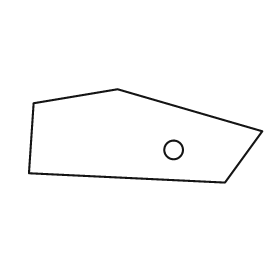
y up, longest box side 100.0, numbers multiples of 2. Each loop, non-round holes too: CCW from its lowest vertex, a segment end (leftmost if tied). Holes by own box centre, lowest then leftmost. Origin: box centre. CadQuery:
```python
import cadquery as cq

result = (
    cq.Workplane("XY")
    .moveTo(34.0, -20.0)
    .lineTo(50.0, 2.0)
    .lineTo(-12.0, 20.0)
    .lineTo(-48.0, 14.0)
    .lineTo(-50.0, -16.0)
    .close()
    .moveTo(12.0, -6.0)
    .circle(4.0)
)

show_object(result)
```